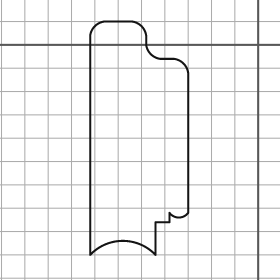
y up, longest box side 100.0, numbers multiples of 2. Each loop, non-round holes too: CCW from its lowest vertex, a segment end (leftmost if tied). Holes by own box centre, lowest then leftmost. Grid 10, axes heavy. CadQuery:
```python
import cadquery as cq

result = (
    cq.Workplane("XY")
    .moveTo(-72.0, -90.0)
    .threePointArc((-58.0, -84.0), (-44.0, -90.0))
    .lineTo(-44.0, -76.0)
    .lineTo(-38.0, -76.0)
    .lineTo(-38.0, -72.0)
    .threePointArc((-34.0, -74.0), (-30.0, -72.0))
    .lineTo(-30.0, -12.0)
    .threePointArc((-32.0, -8.0), (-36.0, -6.0))
    .lineTo(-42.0, -6.0)
    .threePointArc((-46.0, -4.0), (-48.0, 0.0))
    .lineTo(-48.0, 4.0)
    .threePointArc((-50.0, 8.0), (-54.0, 10.0))
    .lineTo(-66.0, 10.0)
    .threePointArc((-70.0, 8.0), (-72.0, 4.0))
    .close()
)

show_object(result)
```